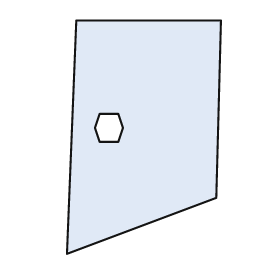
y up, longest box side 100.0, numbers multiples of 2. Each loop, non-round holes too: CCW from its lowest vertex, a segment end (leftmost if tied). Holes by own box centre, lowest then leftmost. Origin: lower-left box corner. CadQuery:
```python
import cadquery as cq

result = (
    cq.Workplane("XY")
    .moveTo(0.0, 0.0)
    .lineTo(64.0, 24.0)
    .lineTo(66.0, 100.0)
    .lineTo(4.0, 100.0)
    .close()
    .moveTo(14.0, 48.0)
    .lineTo(22.0, 48.0)
    .lineTo(24.0, 54.0)
    .lineTo(22.0, 60.0)
    .lineTo(14.0, 60.0)
    .lineTo(12.0, 54.0)
    .close()
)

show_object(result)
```